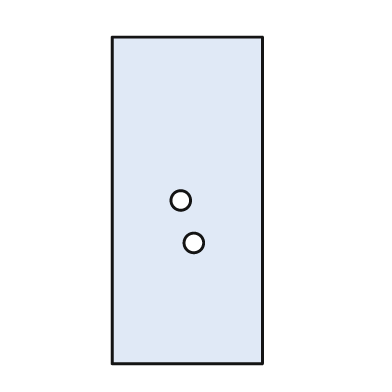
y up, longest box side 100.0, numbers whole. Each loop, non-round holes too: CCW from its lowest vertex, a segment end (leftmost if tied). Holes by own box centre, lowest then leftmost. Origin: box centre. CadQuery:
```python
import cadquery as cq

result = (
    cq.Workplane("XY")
    .moveTo(-23.0, -50.0)
    .lineTo(23.0, -50.0)
    .lineTo(23.0, 50.0)
    .lineTo(-23.0, 50.0)
    .close()
    .moveTo(2.0, -13.0)
    .circle(3.0)
    .moveTo(-2.0, 0.0)
    .circle(3.0)
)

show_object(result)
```